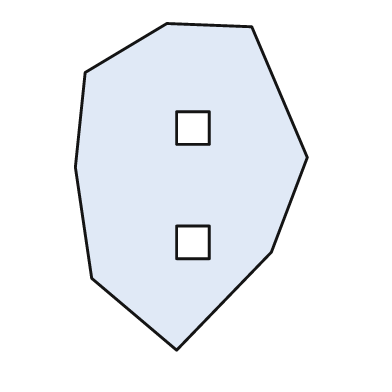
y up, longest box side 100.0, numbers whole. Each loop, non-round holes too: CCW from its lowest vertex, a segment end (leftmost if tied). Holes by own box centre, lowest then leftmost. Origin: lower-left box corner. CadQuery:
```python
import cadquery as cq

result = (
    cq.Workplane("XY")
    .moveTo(31.0, 0.0)
    .lineTo(60.0, 30.0)
    .lineTo(71.0, 59.0)
    .lineTo(54.0, 99.0)
    .lineTo(28.0, 100.0)
    .lineTo(3.0, 85.0)
    .lineTo(0.0, 56.0)
    .lineTo(5.0, 22.0)
    .close()
    .moveTo(31.0, 28.0)
    .lineTo(41.0, 28.0)
    .lineTo(41.0, 38.0)
    .lineTo(31.0, 38.0)
    .close()
    .moveTo(31.0, 63.0)
    .lineTo(41.0, 63.0)
    .lineTo(41.0, 73.0)
    .lineTo(31.0, 73.0)
    .close()
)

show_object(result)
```